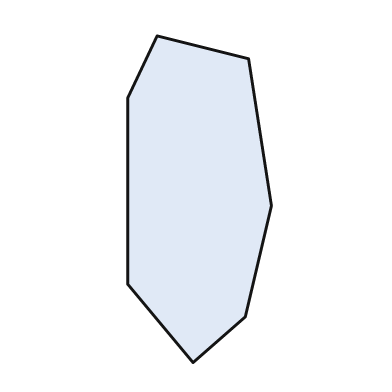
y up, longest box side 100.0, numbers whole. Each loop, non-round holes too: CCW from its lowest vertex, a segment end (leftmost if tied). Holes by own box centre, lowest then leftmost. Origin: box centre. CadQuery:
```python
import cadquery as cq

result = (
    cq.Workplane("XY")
    .moveTo(-2.0, -50.0)
    .lineTo(14.0, -36.0)
    .lineTo(22.0, -2.0)
    .lineTo(15.0, 43.0)
    .lineTo(-13.0, 50.0)
    .lineTo(-22.0, 31.0)
    .lineTo(-22.0, -26.0)
    .close()
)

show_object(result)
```